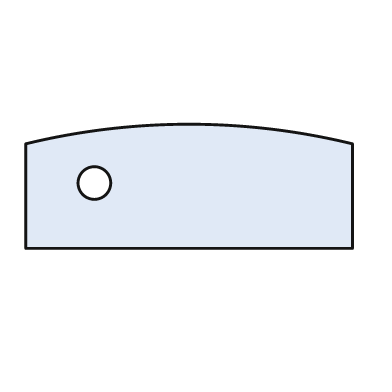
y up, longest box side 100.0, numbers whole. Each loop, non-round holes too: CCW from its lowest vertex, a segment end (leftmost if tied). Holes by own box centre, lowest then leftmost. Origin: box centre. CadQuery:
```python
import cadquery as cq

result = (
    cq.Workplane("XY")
    .moveTo(-50.0, -19.0)
    .lineTo(50.0, -19.0)
    .lineTo(50.0, 13.0)
    .threePointArc((0.0, 19.0), (-50.0, 13.0))
    .close()
    .moveTo(-29.0, 1.0)
    .circle(5.0)
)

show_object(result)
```